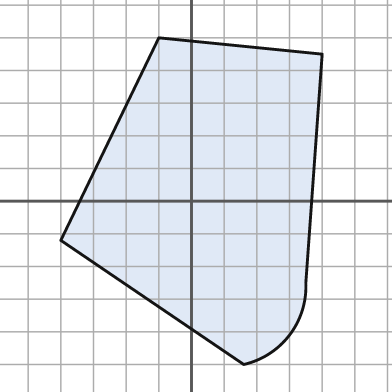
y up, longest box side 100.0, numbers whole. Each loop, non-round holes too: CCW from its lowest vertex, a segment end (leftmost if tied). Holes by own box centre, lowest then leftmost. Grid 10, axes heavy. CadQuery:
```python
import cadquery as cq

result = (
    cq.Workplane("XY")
    .moveTo(16.0, -50.0)
    .threePointArc((30.0, -41.0), (35.0, -25.0))
    .lineTo(40.0, 45.0)
    .lineTo(-10.0, 50.0)
    .lineTo(-40.0, -12.0)
    .close()
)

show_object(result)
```